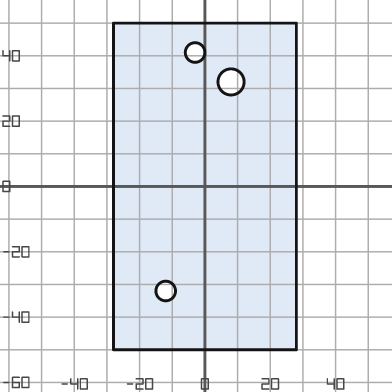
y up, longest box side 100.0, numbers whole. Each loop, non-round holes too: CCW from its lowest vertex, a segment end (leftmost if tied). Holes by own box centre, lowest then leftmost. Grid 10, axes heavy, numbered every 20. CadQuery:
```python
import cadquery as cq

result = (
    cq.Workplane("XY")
    .moveTo(-28.0, -50.0)
    .lineTo(28.0, -50.0)
    .lineTo(28.0, 50.0)
    .lineTo(-28.0, 50.0)
    .close()
    .moveTo(-12.0, -32.0)
    .circle(3.0)
    .moveTo(8.0, 32.0)
    .circle(4.0)
    .moveTo(-3.0, 41.0)
    .circle(3.0)
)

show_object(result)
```